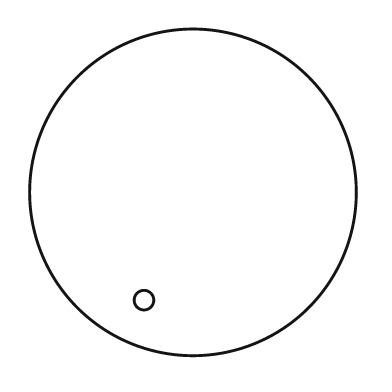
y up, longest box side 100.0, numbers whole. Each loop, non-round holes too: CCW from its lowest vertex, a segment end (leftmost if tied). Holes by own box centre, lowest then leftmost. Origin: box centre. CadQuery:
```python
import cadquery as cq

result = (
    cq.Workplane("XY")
    .moveTo(0.0, 0.0)
    .circle(50.0)
    .moveTo(-15.0, -33.0)
    .circle(3.0)
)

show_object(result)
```